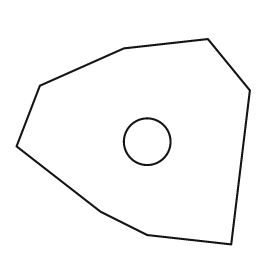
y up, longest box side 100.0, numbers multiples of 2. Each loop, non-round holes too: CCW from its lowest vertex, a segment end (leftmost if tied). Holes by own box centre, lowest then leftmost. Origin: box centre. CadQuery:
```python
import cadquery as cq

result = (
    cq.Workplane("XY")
    .moveTo(42.0, -44.0)
    .lineTo(50.0, 22.0)
    .lineTo(32.0, 44.0)
    .lineTo(-4.0, 40.0)
    .lineTo(-40.0, 24.0)
    .lineTo(-50.0, -2.0)
    .lineTo(-14.0, -30.0)
    .lineTo(6.0, -40.0)
    .close()
    .moveTo(6.0, 0.0)
    .circle(10.0)
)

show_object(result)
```